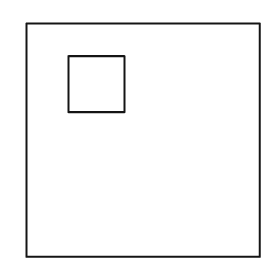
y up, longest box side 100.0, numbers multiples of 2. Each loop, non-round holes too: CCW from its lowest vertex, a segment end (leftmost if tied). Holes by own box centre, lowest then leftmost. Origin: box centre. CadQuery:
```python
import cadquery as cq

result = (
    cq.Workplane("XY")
    .moveTo(-50.0, -50.0)
    .lineTo(50.0, -50.0)
    .lineTo(50.0, 50.0)
    .lineTo(-50.0, 50.0)
    .close()
    .moveTo(-32.0, 12.0)
    .lineTo(-8.0, 12.0)
    .lineTo(-8.0, 36.0)
    .lineTo(-32.0, 36.0)
    .close()
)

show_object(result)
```